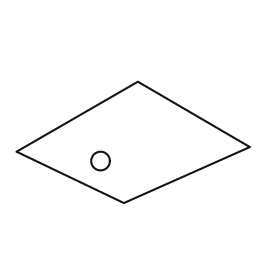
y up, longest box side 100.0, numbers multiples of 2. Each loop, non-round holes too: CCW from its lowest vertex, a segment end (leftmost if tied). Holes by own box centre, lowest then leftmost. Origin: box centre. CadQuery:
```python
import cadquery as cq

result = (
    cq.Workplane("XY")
    .moveTo(-4.0, -26.0)
    .lineTo(50.0, -2.0)
    .lineTo(2.0, 26.0)
    .lineTo(-50.0, -4.0)
    .close()
    .moveTo(-14.0, -8.0)
    .circle(4.0)
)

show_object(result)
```